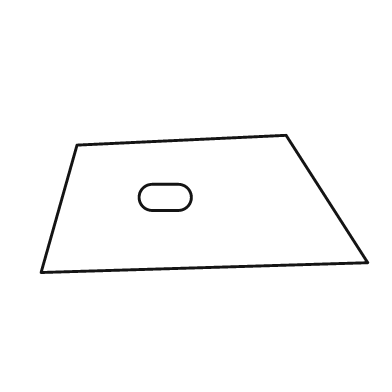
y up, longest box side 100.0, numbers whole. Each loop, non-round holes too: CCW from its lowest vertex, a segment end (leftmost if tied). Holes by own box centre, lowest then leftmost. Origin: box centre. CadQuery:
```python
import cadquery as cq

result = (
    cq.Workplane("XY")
    .moveTo(-50.0, -21.0)
    .lineTo(50.0, -18.0)
    .lineTo(25.0, 21.0)
    .lineTo(-39.0, 18.0)
    .close()
    .moveTo(-16.0, -2.0)
    .lineTo(-8.0, -2.0)
    .threePointArc((-4.0, 2.0), (-8.0, 6.0))
    .lineTo(-16.0, 6.0)
    .threePointArc((-20.0, 2.0), (-16.0, -2.0))
    .close()
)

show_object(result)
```